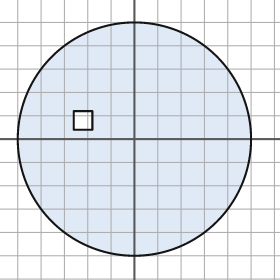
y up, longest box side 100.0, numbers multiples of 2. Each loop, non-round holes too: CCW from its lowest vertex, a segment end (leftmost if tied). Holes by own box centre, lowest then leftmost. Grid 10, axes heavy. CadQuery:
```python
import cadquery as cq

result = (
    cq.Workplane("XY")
    .moveTo(0.0, 0.0)
    .circle(50.0)
    .moveTo(-26.0, 4.0)
    .lineTo(-18.0, 4.0)
    .lineTo(-18.0, 12.0)
    .lineTo(-26.0, 12.0)
    .close()
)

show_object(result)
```